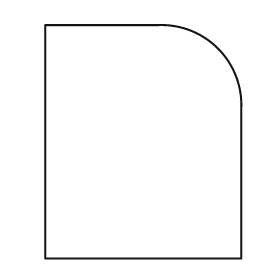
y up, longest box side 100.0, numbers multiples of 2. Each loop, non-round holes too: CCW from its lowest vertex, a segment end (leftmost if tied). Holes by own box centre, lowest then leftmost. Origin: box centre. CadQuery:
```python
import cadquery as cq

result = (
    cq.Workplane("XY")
    .moveTo(-42.0, -50.0)
    .lineTo(42.0, -50.0)
    .lineTo(42.0, 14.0)
    .threePointArc((32.0, 40.0), (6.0, 50.0))
    .lineTo(-42.0, 50.0)
    .close()
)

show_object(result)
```